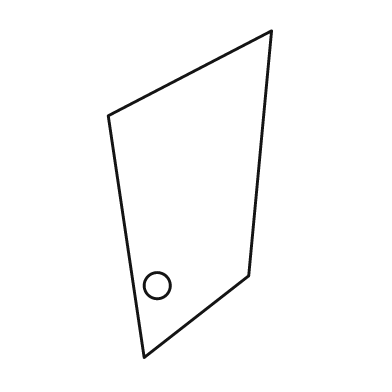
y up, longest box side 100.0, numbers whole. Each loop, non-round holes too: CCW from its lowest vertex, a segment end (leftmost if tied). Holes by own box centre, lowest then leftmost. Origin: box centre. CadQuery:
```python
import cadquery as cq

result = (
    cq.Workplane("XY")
    .moveTo(-14.0, -50.0)
    .lineTo(18.0, -25.0)
    .lineTo(25.0, 50.0)
    .lineTo(-25.0, 24.0)
    .close()
    .moveTo(-10.0, -28.0)
    .circle(4.0)
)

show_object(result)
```